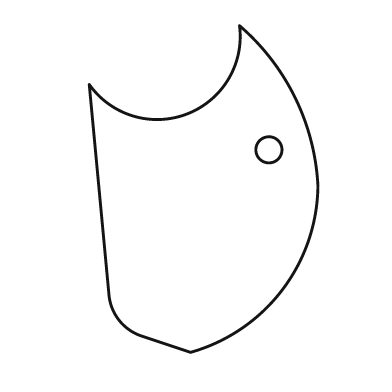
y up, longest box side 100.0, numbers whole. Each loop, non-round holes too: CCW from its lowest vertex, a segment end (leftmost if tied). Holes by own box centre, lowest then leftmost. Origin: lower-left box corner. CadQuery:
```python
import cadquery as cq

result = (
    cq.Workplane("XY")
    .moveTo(31.0, 0.0)
    .threePointArc((59.0, 19.0), (70.0, 51.0))
    .threePointArc((63.0, 78.0), (46.0, 100.0))
    .threePointArc((30.0, 73.0), (0.0, 82.0))
    .lineTo(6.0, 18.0)
    .threePointArc((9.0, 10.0), (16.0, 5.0))
    .close()
    .moveTo(55.0, 62.0)
    .circle(4.0)
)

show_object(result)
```